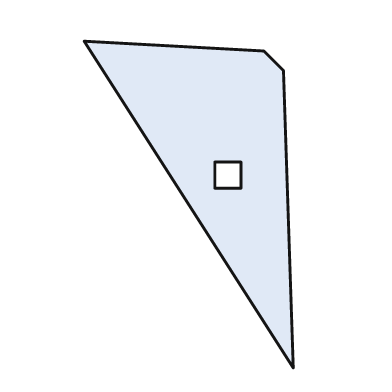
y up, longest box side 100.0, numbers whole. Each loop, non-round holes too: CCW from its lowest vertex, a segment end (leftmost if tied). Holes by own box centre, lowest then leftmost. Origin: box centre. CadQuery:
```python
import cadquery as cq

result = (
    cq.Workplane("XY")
    .moveTo(32.0, -50.0)
    .lineTo(29.0, 41.0)
    .lineTo(23.0, 47.0)
    .lineTo(-32.0, 50.0)
    .close()
    .moveTo(8.0, 5.0)
    .lineTo(16.0, 5.0)
    .lineTo(16.0, 13.0)
    .lineTo(8.0, 13.0)
    .close()
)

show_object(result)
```